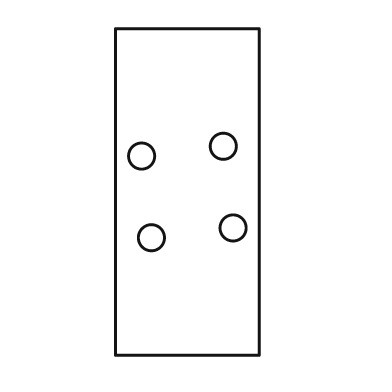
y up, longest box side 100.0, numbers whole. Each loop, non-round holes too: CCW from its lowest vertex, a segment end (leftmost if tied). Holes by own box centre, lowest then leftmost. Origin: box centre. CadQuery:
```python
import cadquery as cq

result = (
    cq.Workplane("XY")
    .moveTo(-22.0, -50.0)
    .lineTo(22.0, -50.0)
    .lineTo(22.0, 50.0)
    .lineTo(-22.0, 50.0)
    .close()
    .moveTo(-11.0, -14.0)
    .circle(4.0)
    .moveTo(14.0, -11.0)
    .circle(4.0)
    .moveTo(-14.0, 11.0)
    .circle(4.0)
    .moveTo(11.0, 14.0)
    .circle(4.0)
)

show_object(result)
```